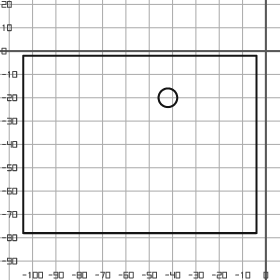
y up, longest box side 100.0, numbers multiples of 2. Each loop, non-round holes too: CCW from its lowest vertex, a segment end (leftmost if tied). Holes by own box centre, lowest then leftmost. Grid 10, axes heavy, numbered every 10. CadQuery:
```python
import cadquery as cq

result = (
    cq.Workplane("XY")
    .moveTo(-104.0, -78.0)
    .lineTo(-4.0, -78.0)
    .lineTo(-4.0, -2.0)
    .lineTo(-104.0, -2.0)
    .close()
    .moveTo(-42.0, -20.0)
    .circle(4.0)
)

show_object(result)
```